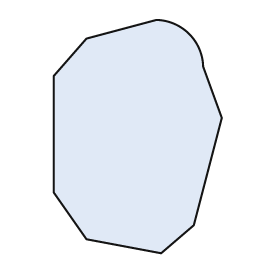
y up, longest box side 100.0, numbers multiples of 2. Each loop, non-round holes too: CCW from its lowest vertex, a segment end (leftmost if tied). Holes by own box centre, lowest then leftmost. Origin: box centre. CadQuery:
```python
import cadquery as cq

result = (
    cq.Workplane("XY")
    .moveTo(10.0, -50.0)
    .lineTo(24.0, -38.0)
    .lineTo(36.0, 8.0)
    .lineTo(28.0, 30.0)
    .threePointArc((22.0, 44.0), (8.0, 50.0))
    .lineTo(-22.0, 42.0)
    .lineTo(-36.0, 26.0)
    .lineTo(-36.0, -24.0)
    .lineTo(-22.0, -44.0)
    .close()
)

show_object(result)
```